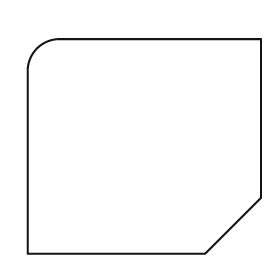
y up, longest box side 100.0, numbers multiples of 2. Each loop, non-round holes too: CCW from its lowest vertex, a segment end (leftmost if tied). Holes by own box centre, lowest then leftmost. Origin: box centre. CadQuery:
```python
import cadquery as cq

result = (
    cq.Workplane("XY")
    .moveTo(-50.0, -46.0)
    .lineTo(26.0, -46.0)
    .lineTo(50.0, -22.0)
    .lineTo(50.0, 46.0)
    .lineTo(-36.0, 46.0)
    .threePointArc((-46.0, 42.0), (-50.0, 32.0))
    .close()
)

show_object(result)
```